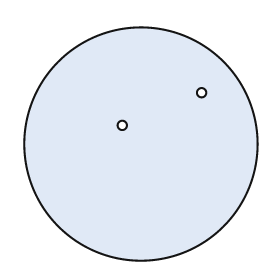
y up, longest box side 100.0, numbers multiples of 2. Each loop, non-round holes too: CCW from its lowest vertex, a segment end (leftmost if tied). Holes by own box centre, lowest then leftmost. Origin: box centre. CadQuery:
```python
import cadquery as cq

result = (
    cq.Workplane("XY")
    .moveTo(0.0, 0.0)
    .circle(50.0)
    .moveTo(-8.0, 8.0)
    .circle(2.0)
    .moveTo(26.0, 22.0)
    .circle(2.0)
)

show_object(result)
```